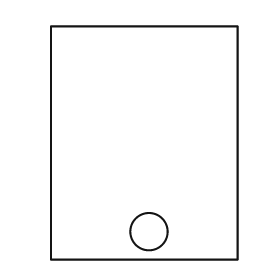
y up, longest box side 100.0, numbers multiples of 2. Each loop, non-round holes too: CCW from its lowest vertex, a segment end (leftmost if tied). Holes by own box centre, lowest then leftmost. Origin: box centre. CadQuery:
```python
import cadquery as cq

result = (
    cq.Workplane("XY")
    .moveTo(-40.0, -50.0)
    .lineTo(40.0, -50.0)
    .lineTo(40.0, 50.0)
    .lineTo(-40.0, 50.0)
    .close()
    .moveTo(2.0, -38.0)
    .circle(8.0)
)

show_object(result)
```